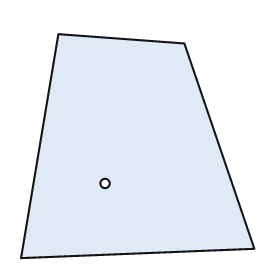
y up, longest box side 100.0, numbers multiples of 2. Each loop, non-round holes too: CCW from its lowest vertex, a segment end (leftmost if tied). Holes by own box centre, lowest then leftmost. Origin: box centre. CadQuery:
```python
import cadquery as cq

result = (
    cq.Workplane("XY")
    .moveTo(-50.0, -48.0)
    .lineTo(50.0, -44.0)
    .lineTo(20.0, 44.0)
    .lineTo(-34.0, 48.0)
    .close()
    .moveTo(-14.0, -16.0)
    .circle(2.0)
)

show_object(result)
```